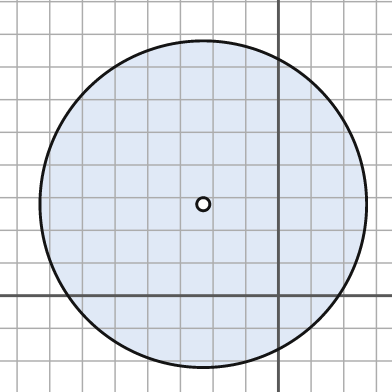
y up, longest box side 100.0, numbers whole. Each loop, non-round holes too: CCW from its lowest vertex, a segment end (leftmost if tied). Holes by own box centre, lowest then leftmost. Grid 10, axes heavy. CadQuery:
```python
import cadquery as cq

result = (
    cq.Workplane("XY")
    .moveTo(-23.0, 28.0)
    .circle(50.0)
    .moveTo(-23.0, 28.0)
    .circle(2.0)
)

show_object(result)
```